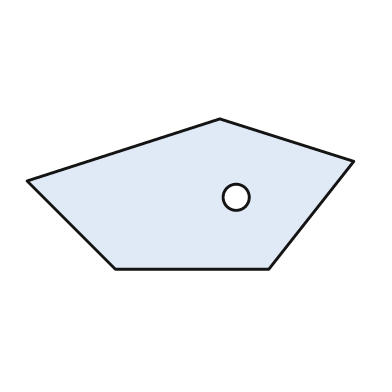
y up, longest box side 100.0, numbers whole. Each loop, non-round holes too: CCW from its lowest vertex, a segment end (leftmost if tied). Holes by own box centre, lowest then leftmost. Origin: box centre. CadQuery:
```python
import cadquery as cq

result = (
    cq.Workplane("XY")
    .moveTo(-23.0, -23.0)
    .lineTo(24.0, -23.0)
    .lineTo(50.0, 10.0)
    .lineTo(9.0, 23.0)
    .lineTo(-50.0, 4.0)
    .close()
    .moveTo(14.0, -1.0)
    .circle(4.0)
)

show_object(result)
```